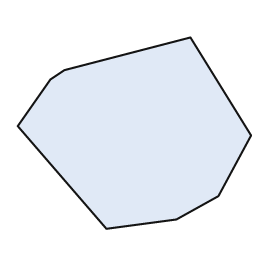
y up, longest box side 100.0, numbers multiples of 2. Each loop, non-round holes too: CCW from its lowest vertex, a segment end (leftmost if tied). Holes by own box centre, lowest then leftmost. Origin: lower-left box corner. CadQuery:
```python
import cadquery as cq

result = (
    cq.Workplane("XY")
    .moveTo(38.0, 0.0)
    .lineTo(68.0, 4.0)
    .lineTo(86.0, 14.0)
    .lineTo(100.0, 40.0)
    .lineTo(74.0, 82.0)
    .lineTo(20.0, 68.0)
    .lineTo(14.0, 64.0)
    .lineTo(0.0, 44.0)
    .close()
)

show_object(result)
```